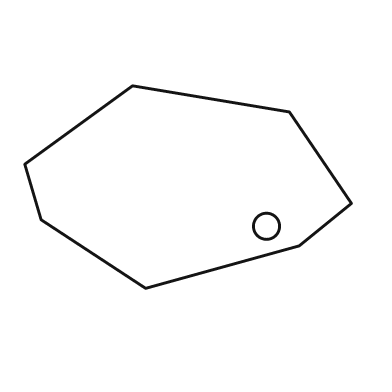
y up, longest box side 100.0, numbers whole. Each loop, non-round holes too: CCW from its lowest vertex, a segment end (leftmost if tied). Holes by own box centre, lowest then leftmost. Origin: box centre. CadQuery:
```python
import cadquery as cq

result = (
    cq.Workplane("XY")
    .moveTo(-13.0, -31.0)
    .lineTo(34.0, -18.0)
    .lineTo(50.0, -5.0)
    .lineTo(31.0, 23.0)
    .lineTo(-17.0, 31.0)
    .lineTo(-50.0, 7.0)
    .lineTo(-45.0, -10.0)
    .close()
    .moveTo(24.0, -12.0)
    .circle(4.0)
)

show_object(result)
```